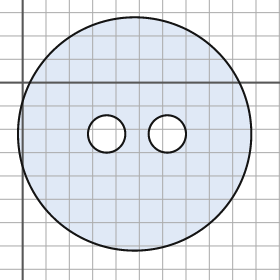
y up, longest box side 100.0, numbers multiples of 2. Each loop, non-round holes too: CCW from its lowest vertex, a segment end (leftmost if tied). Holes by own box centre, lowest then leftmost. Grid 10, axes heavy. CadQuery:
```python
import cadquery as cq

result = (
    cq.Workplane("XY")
    .moveTo(48.0, -22.0)
    .circle(50.0)
    .moveTo(36.0, -22.0)
    .circle(8.0)
    .moveTo(62.0, -22.0)
    .circle(8.0)
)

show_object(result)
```